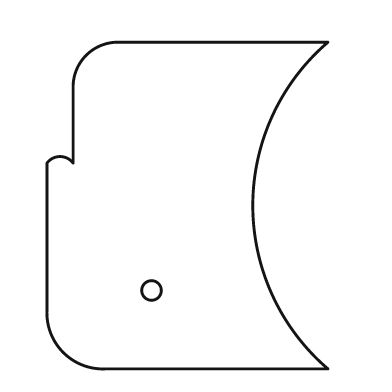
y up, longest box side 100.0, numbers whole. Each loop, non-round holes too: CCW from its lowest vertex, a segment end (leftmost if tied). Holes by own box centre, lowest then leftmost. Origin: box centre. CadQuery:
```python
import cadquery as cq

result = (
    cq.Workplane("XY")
    .moveTo(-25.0, -50.0)
    .lineTo(43.0, -50.0)
    .threePointArc((20.0, 0.0), (43.0, 50.0))
    .lineTo(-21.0, 50.0)
    .threePointArc((-31.0, 46.0), (-35.0, 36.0))
    .lineTo(-35.0, 13.0)
    .threePointArc((-39.0, 15.0), (-43.0, 13.0))
    .lineTo(-43.0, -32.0)
    .threePointArc((-38.0, -45.0), (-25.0, -50.0))
    .close()
    .moveTo(-11.0, -26.0)
    .circle(3.0)
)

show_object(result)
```